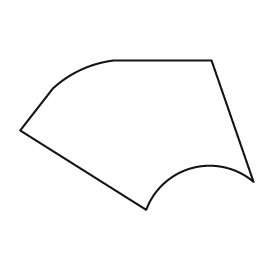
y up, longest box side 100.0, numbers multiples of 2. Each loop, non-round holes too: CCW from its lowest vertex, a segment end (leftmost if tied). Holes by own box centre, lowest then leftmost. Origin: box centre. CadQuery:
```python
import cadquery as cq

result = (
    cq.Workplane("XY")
    .moveTo(4.0, -32.0)
    .threePointArc((24.0, -14.0), (50.0, -20.0))
    .lineTo(32.0, 32.0)
    .lineTo(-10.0, 32.0)
    .threePointArc((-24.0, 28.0), (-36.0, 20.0))
    .lineTo(-50.0, 2.0)
    .close()
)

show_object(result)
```